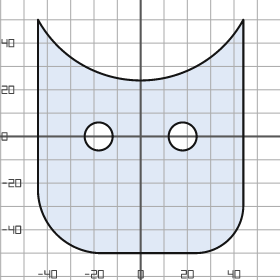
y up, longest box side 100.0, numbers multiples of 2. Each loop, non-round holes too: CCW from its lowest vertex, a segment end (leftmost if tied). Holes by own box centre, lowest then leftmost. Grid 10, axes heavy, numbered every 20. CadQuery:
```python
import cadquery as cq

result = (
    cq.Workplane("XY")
    .moveTo(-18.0, -50.0)
    .lineTo(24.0, -50.0)
    .threePointArc((38.0, -44.0), (44.0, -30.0))
    .lineTo(44.0, 50.0)
    .threePointArc((0.0, 24.0), (-44.0, 50.0))
    .lineTo(-44.0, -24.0)
    .threePointArc((-36.0, -42.0), (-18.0, -50.0))
    .close()
    .moveTo(-18.0, 0.0)
    .circle(6.0)
    .moveTo(18.0, 0.0)
    .circle(6.0)
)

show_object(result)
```